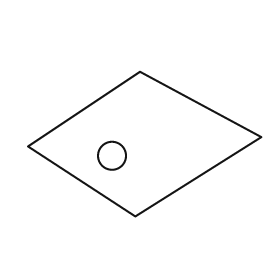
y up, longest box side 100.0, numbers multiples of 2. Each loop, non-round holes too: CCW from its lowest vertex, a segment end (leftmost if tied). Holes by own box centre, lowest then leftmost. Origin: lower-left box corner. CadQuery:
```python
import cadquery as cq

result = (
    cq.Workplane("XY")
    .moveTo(46.0, 0.0)
    .lineTo(100.0, 34.0)
    .lineTo(48.0, 62.0)
    .lineTo(0.0, 30.0)
    .close()
    .moveTo(36.0, 26.0)
    .circle(6.0)
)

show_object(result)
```